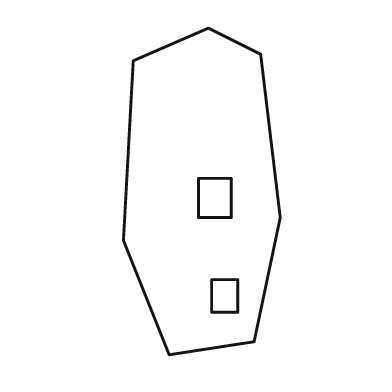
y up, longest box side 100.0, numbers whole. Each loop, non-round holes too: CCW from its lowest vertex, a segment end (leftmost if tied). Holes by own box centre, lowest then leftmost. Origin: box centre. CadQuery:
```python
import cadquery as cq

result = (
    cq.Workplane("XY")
    .moveTo(-10.0, -50.0)
    .lineTo(16.0, -46.0)
    .lineTo(24.0, -8.0)
    .lineTo(18.0, 42.0)
    .lineTo(2.0, 50.0)
    .lineTo(-21.0, 40.0)
    .lineTo(-24.0, -15.0)
    .close()
    .moveTo(3.0, -37.0)
    .lineTo(11.0, -37.0)
    .lineTo(11.0, -27.0)
    .lineTo(3.0, -27.0)
    .close()
    .moveTo(-1.0, -8.0)
    .lineTo(9.0, -8.0)
    .lineTo(9.0, 4.0)
    .lineTo(-1.0, 4.0)
    .close()
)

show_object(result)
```